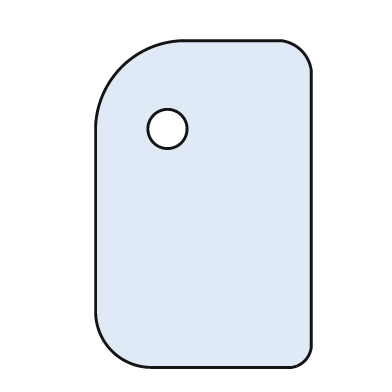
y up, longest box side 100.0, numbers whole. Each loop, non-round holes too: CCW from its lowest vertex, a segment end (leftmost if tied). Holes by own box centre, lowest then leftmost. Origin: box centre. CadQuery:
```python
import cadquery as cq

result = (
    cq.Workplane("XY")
    .moveTo(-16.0, -50.0)
    .lineTo(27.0, -50.0)
    .threePointArc((31.0, -48.0), (33.0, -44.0))
    .lineTo(33.0, 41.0)
    .threePointArc((30.0, 47.0), (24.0, 50.0))
    .lineTo(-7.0, 50.0)
    .threePointArc((-25.0, 42.0), (-33.0, 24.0))
    .lineTo(-33.0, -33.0)
    .threePointArc((-28.0, -45.0), (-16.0, -50.0))
    .close()
    .moveTo(-11.0, 23.0)
    .circle(6.0)
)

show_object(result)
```